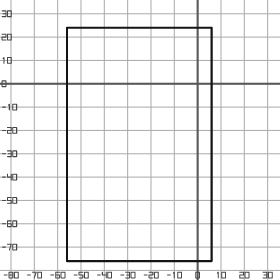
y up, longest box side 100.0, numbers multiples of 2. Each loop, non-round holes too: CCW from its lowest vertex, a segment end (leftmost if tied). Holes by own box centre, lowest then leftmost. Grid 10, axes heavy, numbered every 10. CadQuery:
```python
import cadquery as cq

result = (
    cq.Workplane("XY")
    .moveTo(-56.0, -76.0)
    .lineTo(6.0, -76.0)
    .lineTo(6.0, 24.0)
    .lineTo(-56.0, 24.0)
    .close()
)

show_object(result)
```